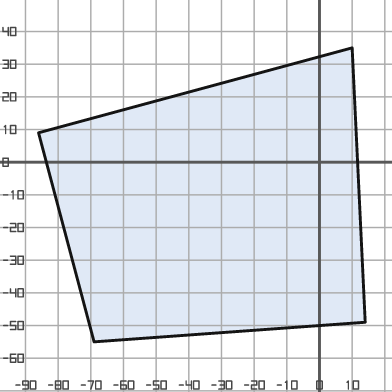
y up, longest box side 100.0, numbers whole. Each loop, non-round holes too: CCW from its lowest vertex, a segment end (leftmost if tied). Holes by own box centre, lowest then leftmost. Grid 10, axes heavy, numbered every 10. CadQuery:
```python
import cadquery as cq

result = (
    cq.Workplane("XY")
    .moveTo(-69.0, -55.0)
    .lineTo(14.0, -49.0)
    .lineTo(10.0, 35.0)
    .lineTo(-86.0, 9.0)
    .close()
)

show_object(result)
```